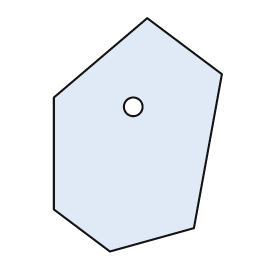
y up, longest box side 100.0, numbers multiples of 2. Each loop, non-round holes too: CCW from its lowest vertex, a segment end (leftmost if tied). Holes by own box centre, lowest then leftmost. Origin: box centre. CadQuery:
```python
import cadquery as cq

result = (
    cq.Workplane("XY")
    .moveTo(-12.0, -50.0)
    .lineTo(24.0, -40.0)
    .lineTo(36.0, 26.0)
    .lineTo(4.0, 50.0)
    .lineTo(-36.0, 16.0)
    .lineTo(-36.0, -32.0)
    .close()
    .moveTo(-2.0, 12.0)
    .circle(4.0)
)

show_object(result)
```